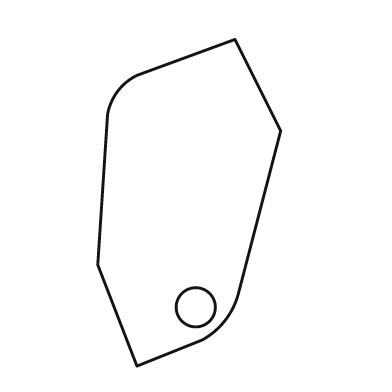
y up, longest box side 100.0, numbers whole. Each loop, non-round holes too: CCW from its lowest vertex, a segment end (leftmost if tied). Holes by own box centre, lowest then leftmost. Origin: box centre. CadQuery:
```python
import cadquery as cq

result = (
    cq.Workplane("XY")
    .moveTo(-16.0, -50.0)
    .lineTo(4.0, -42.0)
    .threePointArc((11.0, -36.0), (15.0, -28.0))
    .lineTo(28.0, 22.0)
    .lineTo(14.0, 50.0)
    .lineTo(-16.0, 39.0)
    .threePointArc((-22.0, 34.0), (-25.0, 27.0))
    .lineTo(-28.0, -19.0)
    .close()
    .moveTo(2.0, -32.0)
    .circle(6.0)
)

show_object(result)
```